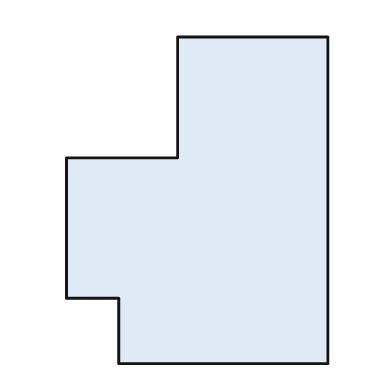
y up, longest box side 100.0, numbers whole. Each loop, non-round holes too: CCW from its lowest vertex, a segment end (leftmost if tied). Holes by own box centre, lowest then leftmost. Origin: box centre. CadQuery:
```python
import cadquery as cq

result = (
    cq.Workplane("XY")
    .moveTo(-24.0, -50.0)
    .lineTo(40.0, -50.0)
    .lineTo(40.0, 50.0)
    .lineTo(-6.0, 50.0)
    .lineTo(-6.0, 13.0)
    .lineTo(-40.0, 13.0)
    .lineTo(-40.0, -30.0)
    .lineTo(-24.0, -30.0)
    .close()
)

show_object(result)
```